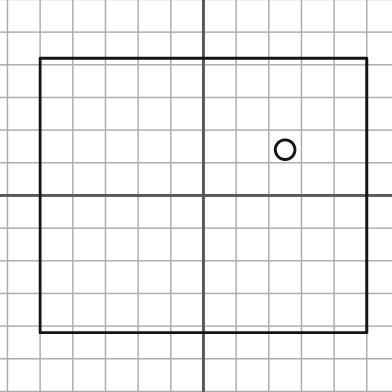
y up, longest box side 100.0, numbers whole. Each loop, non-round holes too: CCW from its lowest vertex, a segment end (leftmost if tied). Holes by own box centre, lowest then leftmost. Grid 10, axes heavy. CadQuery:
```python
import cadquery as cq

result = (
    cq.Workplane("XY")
    .moveTo(-50.0, -42.0)
    .lineTo(50.0, -42.0)
    .lineTo(50.0, 42.0)
    .lineTo(-50.0, 42.0)
    .close()
    .moveTo(25.0, 14.0)
    .circle(3.0)
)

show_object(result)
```